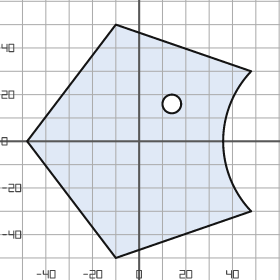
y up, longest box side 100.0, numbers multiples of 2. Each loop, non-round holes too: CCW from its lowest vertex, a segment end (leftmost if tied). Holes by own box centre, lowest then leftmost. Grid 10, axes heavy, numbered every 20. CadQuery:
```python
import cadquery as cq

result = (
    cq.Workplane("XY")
    .moveTo(-10.0, -50.0)
    .lineTo(48.0, -30.0)
    .threePointArc((36.0, 0.0), (48.0, 30.0))
    .lineTo(-10.0, 50.0)
    .lineTo(-48.0, 0.0)
    .close()
    .moveTo(14.0, 16.0)
    .circle(4.0)
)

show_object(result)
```